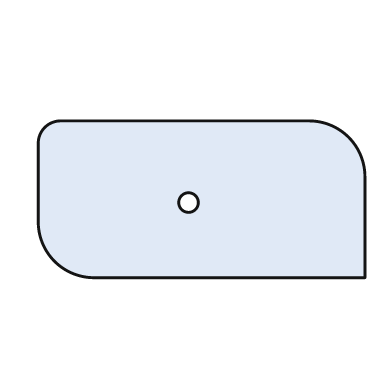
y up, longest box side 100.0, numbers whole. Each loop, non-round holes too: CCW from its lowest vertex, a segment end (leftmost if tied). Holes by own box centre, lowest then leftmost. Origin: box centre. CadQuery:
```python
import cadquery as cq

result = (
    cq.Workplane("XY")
    .moveTo(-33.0, -24.0)
    .lineTo(50.0, -24.0)
    .lineTo(50.0, 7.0)
    .threePointArc((45.0, 19.0), (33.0, 24.0))
    .lineTo(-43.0, 24.0)
    .threePointArc((-48.0, 22.0), (-50.0, 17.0))
    .lineTo(-50.0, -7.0)
    .threePointArc((-45.0, -19.0), (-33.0, -24.0))
    .close()
    .moveTo(-4.0, -1.0)
    .circle(3.0)
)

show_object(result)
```